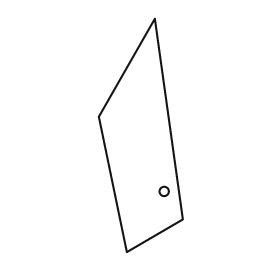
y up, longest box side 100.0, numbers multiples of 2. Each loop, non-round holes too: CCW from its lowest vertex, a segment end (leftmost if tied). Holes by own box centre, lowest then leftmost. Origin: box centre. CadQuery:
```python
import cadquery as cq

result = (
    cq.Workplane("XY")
    .moveTo(-6.0, -50.0)
    .lineTo(18.0, -36.0)
    .lineTo(6.0, 50.0)
    .lineTo(-18.0, 8.0)
    .close()
    .moveTo(10.0, -24.0)
    .circle(2.0)
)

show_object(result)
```